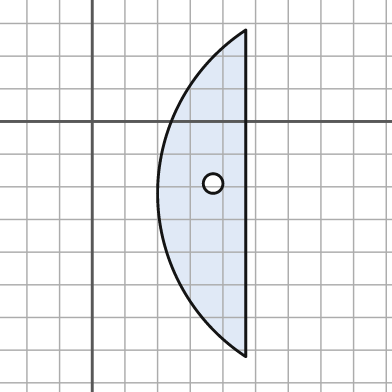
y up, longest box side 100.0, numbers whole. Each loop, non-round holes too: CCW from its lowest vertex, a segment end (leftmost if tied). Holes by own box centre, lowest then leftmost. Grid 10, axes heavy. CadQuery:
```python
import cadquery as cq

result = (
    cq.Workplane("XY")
    .moveTo(47.0, -72.0)
    .lineTo(47.0, 28.0)
    .threePointArc((20.0, -22.0), (47.0, -72.0))
    .close()
    .moveTo(37.0, -19.0)
    .circle(3.0)
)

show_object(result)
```